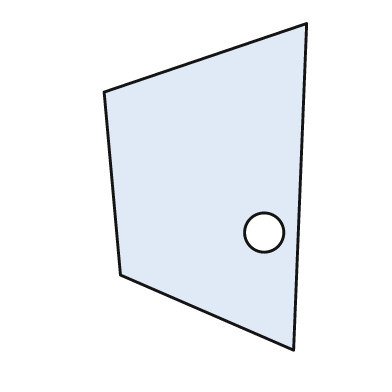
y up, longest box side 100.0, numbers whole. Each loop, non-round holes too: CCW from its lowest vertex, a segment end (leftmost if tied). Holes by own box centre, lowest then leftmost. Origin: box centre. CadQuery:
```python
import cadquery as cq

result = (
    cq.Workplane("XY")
    .moveTo(27.0, -50.0)
    .lineTo(31.0, 50.0)
    .lineTo(-31.0, 29.0)
    .lineTo(-26.0, -27.0)
    .close()
    .moveTo(18.0, -14.0)
    .circle(6.0)
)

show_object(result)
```